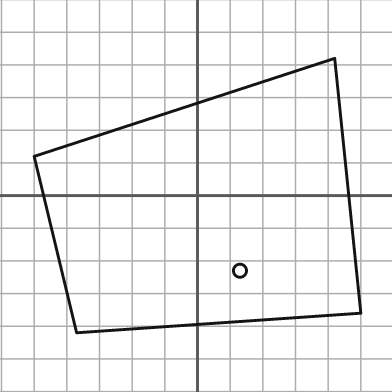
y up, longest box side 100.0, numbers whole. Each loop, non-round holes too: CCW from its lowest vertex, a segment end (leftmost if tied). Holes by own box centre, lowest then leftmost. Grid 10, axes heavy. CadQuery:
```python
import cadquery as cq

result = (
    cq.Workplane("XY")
    .moveTo(-37.0, -42.0)
    .lineTo(50.0, -36.0)
    .lineTo(42.0, 42.0)
    .lineTo(-50.0, 12.0)
    .close()
    .moveTo(13.0, -23.0)
    .circle(2.0)
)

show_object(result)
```